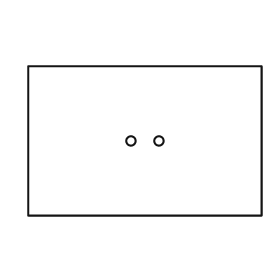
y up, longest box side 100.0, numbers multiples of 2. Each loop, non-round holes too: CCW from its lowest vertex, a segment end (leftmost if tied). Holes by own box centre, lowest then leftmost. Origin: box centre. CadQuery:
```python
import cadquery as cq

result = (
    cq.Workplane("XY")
    .moveTo(-50.0, -32.0)
    .lineTo(50.0, -32.0)
    .lineTo(50.0, 32.0)
    .lineTo(-50.0, 32.0)
    .close()
    .moveTo(-6.0, 0.0)
    .circle(2.0)
    .moveTo(6.0, 0.0)
    .circle(2.0)
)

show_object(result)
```